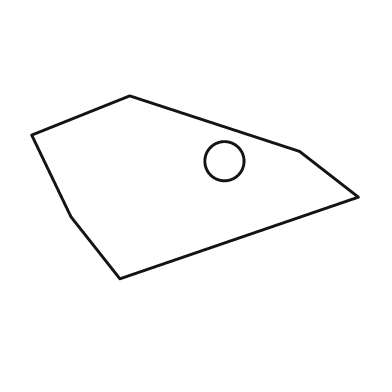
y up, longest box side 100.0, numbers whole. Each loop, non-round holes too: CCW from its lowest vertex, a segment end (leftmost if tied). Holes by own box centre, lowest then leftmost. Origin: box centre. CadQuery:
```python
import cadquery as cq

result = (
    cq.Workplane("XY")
    .moveTo(-23.0, -28.0)
    .lineTo(50.0, -3.0)
    .lineTo(32.0, 11.0)
    .lineTo(-20.0, 28.0)
    .lineTo(-50.0, 16.0)
    .lineTo(-38.0, -9.0)
    .close()
    .moveTo(9.0, 8.0)
    .circle(6.0)
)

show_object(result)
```